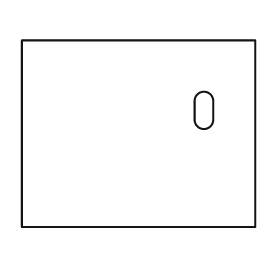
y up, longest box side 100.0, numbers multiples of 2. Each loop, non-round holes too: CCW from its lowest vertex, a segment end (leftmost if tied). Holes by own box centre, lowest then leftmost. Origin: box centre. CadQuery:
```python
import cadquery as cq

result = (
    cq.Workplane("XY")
    .moveTo(-50.0, -40.0)
    .lineTo(50.0, -40.0)
    .lineTo(50.0, 40.0)
    .lineTo(-50.0, 40.0)
    .close()
    .moveTo(24.0, 6.0)
    .threePointArc((28.0, 2.0), (32.0, 6.0))
    .lineTo(32.0, 14.0)
    .threePointArc((28.0, 18.0), (24.0, 14.0))
    .close()
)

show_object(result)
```